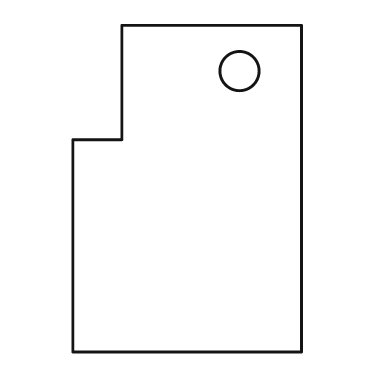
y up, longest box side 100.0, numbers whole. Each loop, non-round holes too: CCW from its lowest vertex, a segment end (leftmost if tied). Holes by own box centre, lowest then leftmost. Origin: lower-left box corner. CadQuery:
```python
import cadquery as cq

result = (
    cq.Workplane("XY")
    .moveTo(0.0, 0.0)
    .lineTo(70.0, 0.0)
    .lineTo(70.0, 100.0)
    .lineTo(15.0, 100.0)
    .lineTo(15.0, 65.0)
    .lineTo(0.0, 65.0)
    .close()
    .moveTo(51.0, 86.0)
    .circle(6.0)
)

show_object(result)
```